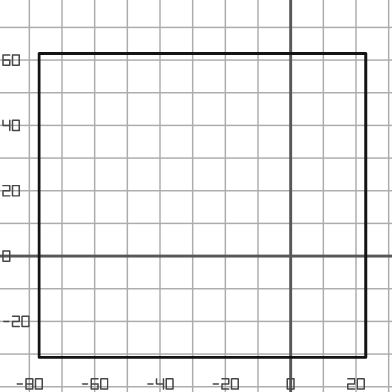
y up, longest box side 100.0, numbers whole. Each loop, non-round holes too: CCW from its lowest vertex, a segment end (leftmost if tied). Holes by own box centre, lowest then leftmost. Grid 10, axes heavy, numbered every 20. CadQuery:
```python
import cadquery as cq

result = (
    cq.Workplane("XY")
    .moveTo(-77.0, -31.0)
    .lineTo(23.0, -31.0)
    .lineTo(23.0, 62.0)
    .lineTo(-77.0, 62.0)
    .close()
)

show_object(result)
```